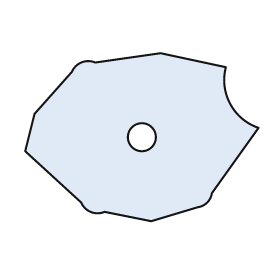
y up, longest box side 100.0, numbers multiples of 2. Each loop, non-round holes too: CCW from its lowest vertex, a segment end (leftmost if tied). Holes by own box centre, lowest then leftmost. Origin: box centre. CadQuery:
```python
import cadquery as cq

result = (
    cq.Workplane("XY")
    .moveTo(4.0, -36.0)
    .lineTo(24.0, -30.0)
    .threePointArc((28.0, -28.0), (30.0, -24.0))
    .lineTo(50.0, 4.0)
    .threePointArc((38.0, 14.0), (36.0, 30.0))
    .lineTo(8.0, 36.0)
    .lineTo(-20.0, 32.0)
    .threePointArc((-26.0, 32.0), (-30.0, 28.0))
    .lineTo(-46.0, 10.0)
    .lineTo(-50.0, -6.0)
    .lineTo(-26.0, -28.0)
    .threePointArc((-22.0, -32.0), (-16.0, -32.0))
    .close()
    .moveTo(0.0, 0.0)
    .circle(6.0)
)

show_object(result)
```